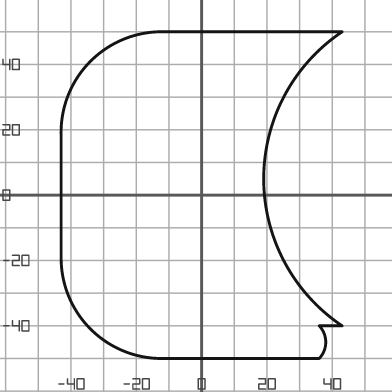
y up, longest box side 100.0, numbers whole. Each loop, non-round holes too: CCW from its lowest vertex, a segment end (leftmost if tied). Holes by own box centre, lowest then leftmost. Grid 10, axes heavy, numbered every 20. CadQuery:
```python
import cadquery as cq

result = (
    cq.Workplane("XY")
    .moveTo(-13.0, -50.0)
    .lineTo(36.0, -50.0)
    .threePointArc((38.0, -45.0), (36.0, -40.0))
    .lineTo(43.0, -40.0)
    .threePointArc((19.0, 5.0), (43.0, 50.0))
    .lineTo(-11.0, 50.0)
    .threePointArc((-34.0, 41.0), (-43.0, 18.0))
    .lineTo(-43.0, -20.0)
    .threePointArc((-34.0, -41.0), (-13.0, -50.0))
    .close()
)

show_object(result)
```